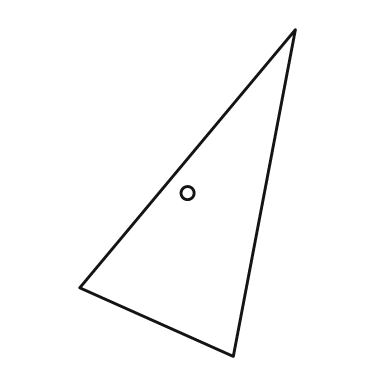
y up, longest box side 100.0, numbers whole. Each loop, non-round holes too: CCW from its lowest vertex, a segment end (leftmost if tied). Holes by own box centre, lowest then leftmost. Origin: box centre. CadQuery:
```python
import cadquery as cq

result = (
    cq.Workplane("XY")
    .moveTo(14.0, -50.0)
    .lineTo(33.0, 50.0)
    .lineTo(-33.0, -29.0)
    .close()
    .moveTo(0.0, 0.0)
    .circle(2.0)
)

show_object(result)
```